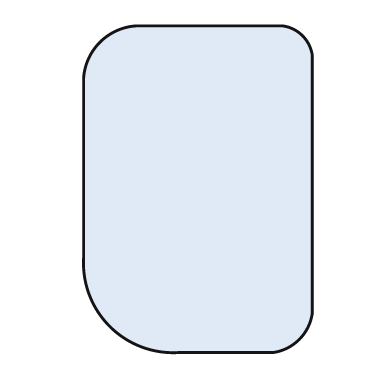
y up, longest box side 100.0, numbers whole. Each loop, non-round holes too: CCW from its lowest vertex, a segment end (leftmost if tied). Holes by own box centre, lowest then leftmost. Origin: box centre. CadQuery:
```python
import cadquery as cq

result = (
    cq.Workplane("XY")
    .moveTo(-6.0, -50.0)
    .lineTo(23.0, -50.0)
    .threePointArc((31.0, -46.0), (35.0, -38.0))
    .lineTo(35.0, 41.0)
    .threePointArc((32.0, 47.0), (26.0, 50.0))
    .lineTo(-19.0, 50.0)
    .threePointArc((-30.0, 45.0), (-35.0, 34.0))
    .lineTo(-35.0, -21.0)
    .threePointArc((-27.0, -42.0), (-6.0, -50.0))
    .close()
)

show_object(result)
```